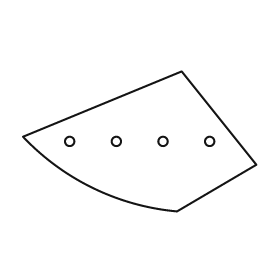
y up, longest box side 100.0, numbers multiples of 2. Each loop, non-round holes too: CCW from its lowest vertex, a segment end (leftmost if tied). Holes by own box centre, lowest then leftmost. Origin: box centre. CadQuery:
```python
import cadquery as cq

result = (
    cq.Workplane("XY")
    .moveTo(16.0, -30.0)
    .lineTo(50.0, -10.0)
    .lineTo(18.0, 30.0)
    .lineTo(-50.0, 2.0)
    .threePointArc((-20.0, -20.0), (16.0, -30.0))
    .close()
    .moveTo(-30.0, 0.0)
    .circle(2.0)
    .moveTo(-10.0, 0.0)
    .circle(2.0)
    .moveTo(10.0, 0.0)
    .circle(2.0)
    .moveTo(30.0, 0.0)
    .circle(2.0)
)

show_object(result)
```